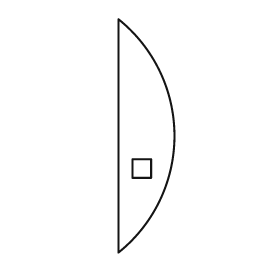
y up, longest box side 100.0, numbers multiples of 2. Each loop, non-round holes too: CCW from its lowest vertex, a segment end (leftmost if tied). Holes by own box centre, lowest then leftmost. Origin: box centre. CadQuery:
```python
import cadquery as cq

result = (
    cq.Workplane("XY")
    .moveTo(-12.0, -50.0)
    .threePointArc((12.0, 0.0), (-12.0, 50.0))
    .close()
    .moveTo(-6.0, -18.0)
    .lineTo(2.0, -18.0)
    .lineTo(2.0, -10.0)
    .lineTo(-6.0, -10.0)
    .close()
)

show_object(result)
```